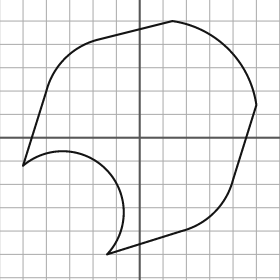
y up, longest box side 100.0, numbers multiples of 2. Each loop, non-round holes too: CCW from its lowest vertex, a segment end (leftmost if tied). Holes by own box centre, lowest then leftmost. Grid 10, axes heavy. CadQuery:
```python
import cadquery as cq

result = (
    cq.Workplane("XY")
    .moveTo(-14.0, -50.0)
    .lineTo(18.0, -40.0)
    .threePointArc((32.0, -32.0), (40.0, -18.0))
    .lineTo(50.0, 14.0)
    .threePointArc((38.0, 38.0), (14.0, 50.0))
    .lineTo(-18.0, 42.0)
    .threePointArc((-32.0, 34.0), (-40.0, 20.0))
    .lineTo(-50.0, -12.0)
    .threePointArc((-14.0, -14.0), (-14.0, -50.0))
    .close()
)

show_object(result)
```